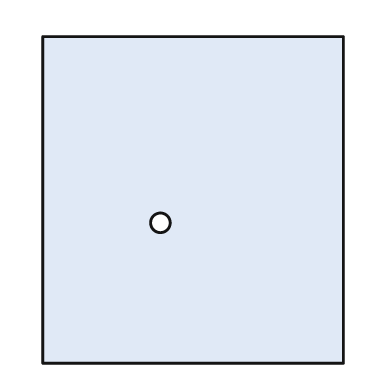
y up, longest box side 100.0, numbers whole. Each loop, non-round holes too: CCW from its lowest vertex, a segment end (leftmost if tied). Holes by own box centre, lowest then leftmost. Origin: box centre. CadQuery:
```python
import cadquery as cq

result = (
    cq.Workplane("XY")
    .moveTo(-46.0, -50.0)
    .lineTo(46.0, -50.0)
    .lineTo(46.0, 50.0)
    .lineTo(-46.0, 50.0)
    .close()
    .moveTo(-10.0, -7.0)
    .circle(3.0)
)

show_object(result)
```